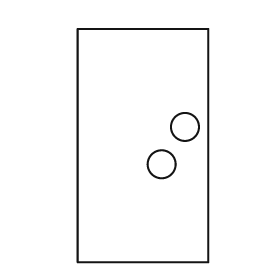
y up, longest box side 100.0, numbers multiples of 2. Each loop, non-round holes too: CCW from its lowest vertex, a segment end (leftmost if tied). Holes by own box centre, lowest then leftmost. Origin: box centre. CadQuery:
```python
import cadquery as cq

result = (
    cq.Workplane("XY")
    .moveTo(-28.0, -50.0)
    .lineTo(28.0, -50.0)
    .lineTo(28.0, 50.0)
    .lineTo(-28.0, 50.0)
    .close()
    .moveTo(8.0, -8.0)
    .circle(6.0)
    .moveTo(18.0, 8.0)
    .circle(6.0)
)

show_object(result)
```